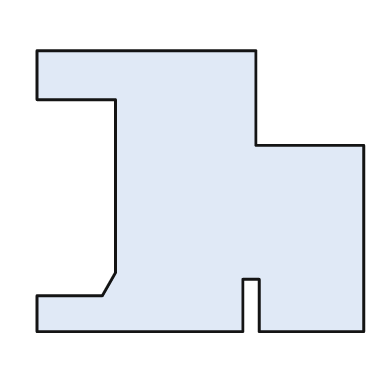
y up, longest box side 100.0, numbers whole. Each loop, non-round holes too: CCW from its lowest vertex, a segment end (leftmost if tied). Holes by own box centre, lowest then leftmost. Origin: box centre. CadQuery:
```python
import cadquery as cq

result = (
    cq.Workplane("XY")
    .moveTo(-50.0, -43.0)
    .lineTo(13.0, -43.0)
    .lineTo(13.0, -27.0)
    .lineTo(18.0, -27.0)
    .lineTo(18.0, -43.0)
    .lineTo(50.0, -43.0)
    .lineTo(50.0, 14.0)
    .lineTo(17.0, 14.0)
    .lineTo(17.0, 43.0)
    .lineTo(-50.0, 43.0)
    .lineTo(-50.0, 28.0)
    .lineTo(-26.0, 28.0)
    .lineTo(-26.0, -25.0)
    .lineTo(-30.0, -32.0)
    .lineTo(-50.0, -32.0)
    .close()
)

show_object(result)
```